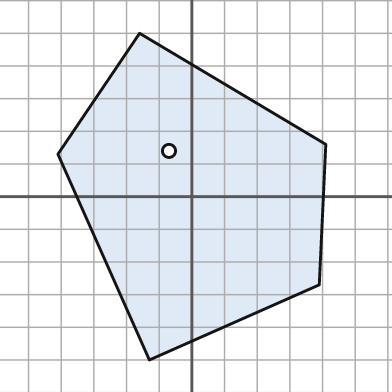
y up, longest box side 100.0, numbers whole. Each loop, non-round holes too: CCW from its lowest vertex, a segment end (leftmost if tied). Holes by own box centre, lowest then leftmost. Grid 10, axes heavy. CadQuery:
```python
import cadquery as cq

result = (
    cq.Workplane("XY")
    .moveTo(-13.0, -50.0)
    .lineTo(39.0, -27.0)
    .lineTo(41.0, 16.0)
    .lineTo(-16.0, 50.0)
    .lineTo(-41.0, 13.0)
    .close()
    .moveTo(-7.0, 14.0)
    .circle(2.0)
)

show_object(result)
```